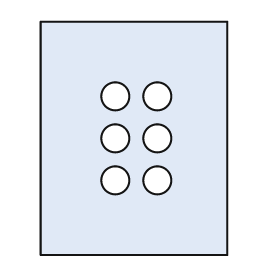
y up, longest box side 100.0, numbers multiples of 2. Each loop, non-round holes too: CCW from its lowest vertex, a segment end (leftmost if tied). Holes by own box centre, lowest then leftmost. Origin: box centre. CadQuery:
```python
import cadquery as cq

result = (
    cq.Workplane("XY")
    .moveTo(-40.0, -50.0)
    .lineTo(40.0, -50.0)
    .lineTo(40.0, 50.0)
    .lineTo(-40.0, 50.0)
    .close()
    .moveTo(-8.0, -18.0)
    .circle(6.0)
    .moveTo(10.0, -18.0)
    .circle(6.0)
    .moveTo(-8.0, 0.0)
    .circle(6.0)
    .moveTo(10.0, 0.0)
    .circle(6.0)
    .moveTo(-8.0, 18.0)
    .circle(6.0)
    .moveTo(10.0, 18.0)
    .circle(6.0)
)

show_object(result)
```